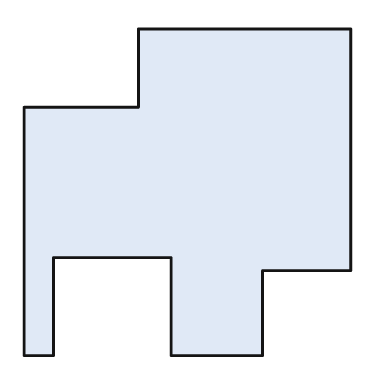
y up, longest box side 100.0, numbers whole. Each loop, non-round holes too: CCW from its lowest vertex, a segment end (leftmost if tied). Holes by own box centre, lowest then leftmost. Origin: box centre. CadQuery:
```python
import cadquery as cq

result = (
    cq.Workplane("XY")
    .moveTo(-50.0, -50.0)
    .lineTo(-41.0, -50.0)
    .lineTo(-41.0, -20.0)
    .lineTo(-5.0, -20.0)
    .lineTo(-5.0, -50.0)
    .lineTo(23.0, -50.0)
    .lineTo(23.0, -24.0)
    .lineTo(50.0, -24.0)
    .lineTo(50.0, 50.0)
    .lineTo(-15.0, 50.0)
    .lineTo(-15.0, 26.0)
    .lineTo(-50.0, 26.0)
    .close()
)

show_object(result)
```